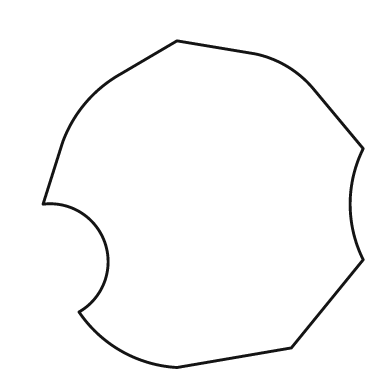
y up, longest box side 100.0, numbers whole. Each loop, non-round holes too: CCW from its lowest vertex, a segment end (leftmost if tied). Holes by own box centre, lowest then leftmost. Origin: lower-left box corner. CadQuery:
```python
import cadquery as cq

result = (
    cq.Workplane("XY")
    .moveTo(41.0, 0.0)
    .lineTo(76.0, 6.0)
    .lineTo(98.0, 33.0)
    .threePointArc((94.0, 50.0), (98.0, 67.0))
    .lineTo(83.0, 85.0)
    .threePointArc((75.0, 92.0), (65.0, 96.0))
    .lineTo(41.0, 100.0)
    .lineTo(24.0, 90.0)
    .threePointArc((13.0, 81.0), (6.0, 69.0))
    .lineTo(0.0, 50.0)
    .threePointArc((19.0, 38.0), (11.0, 17.0))
    .threePointArc((24.0, 5.0), (41.0, 0.0))
    .close()
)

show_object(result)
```